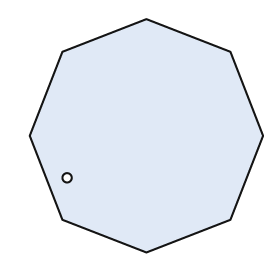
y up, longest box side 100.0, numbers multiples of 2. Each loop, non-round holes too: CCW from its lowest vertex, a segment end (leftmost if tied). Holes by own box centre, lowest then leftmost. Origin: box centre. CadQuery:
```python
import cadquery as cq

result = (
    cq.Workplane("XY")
    .moveTo(0.0, -50.0)
    .lineTo(36.0, -36.0)
    .lineTo(50.0, 0.0)
    .lineTo(36.0, 36.0)
    .lineTo(0.0, 50.0)
    .lineTo(-36.0, 36.0)
    .lineTo(-50.0, 0.0)
    .lineTo(-36.0, -36.0)
    .close()
    .moveTo(-34.0, -18.0)
    .circle(2.0)
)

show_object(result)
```